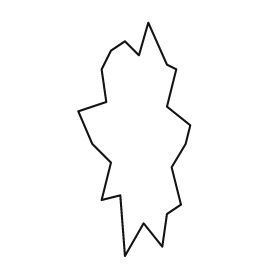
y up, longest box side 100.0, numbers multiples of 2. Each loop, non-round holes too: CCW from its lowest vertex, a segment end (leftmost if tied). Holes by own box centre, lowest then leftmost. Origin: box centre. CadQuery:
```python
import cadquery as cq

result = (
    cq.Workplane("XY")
    .moveTo(-4.0, -50.0)
    .lineTo(4.0, -36.0)
    .lineTo(12.0, -46.0)
    .lineTo(14.0, -32.0)
    .lineTo(20.0, -28.0)
    .lineTo(16.0, -12.0)
    .lineTo(22.0, -2.0)
    .lineTo(24.0, 6.0)
    .lineTo(14.0, 14.0)
    .lineTo(18.0, 30.0)
    .lineTo(14.0, 32.0)
    .lineTo(6.0, 50.0)
    .lineTo(2.0, 36.0)
    .lineTo(-4.0, 42.0)
    .lineTo(-10.0, 38.0)
    .lineTo(-14.0, 30.0)
    .lineTo(-12.0, 16.0)
    .lineTo(-24.0, 12.0)
    .lineTo(-18.0, -2.0)
    .lineTo(-10.0, -10.0)
    .lineTo(-14.0, -26.0)
    .lineTo(-6.0, -24.0)
    .close()
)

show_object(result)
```